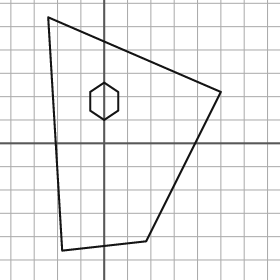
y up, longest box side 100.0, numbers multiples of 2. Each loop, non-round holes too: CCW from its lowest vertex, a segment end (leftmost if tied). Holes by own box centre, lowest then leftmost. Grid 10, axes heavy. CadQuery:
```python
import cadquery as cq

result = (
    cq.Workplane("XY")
    .moveTo(-18.0, -46.0)
    .lineTo(18.0, -42.0)
    .lineTo(50.0, 22.0)
    .lineTo(-24.0, 54.0)
    .close()
    .moveTo(0.0, 10.0)
    .lineTo(6.0, 14.0)
    .lineTo(6.0, 22.0)
    .lineTo(0.0, 26.0)
    .lineTo(-6.0, 22.0)
    .lineTo(-6.0, 14.0)
    .close()
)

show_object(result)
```